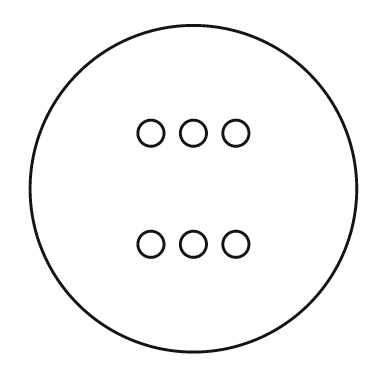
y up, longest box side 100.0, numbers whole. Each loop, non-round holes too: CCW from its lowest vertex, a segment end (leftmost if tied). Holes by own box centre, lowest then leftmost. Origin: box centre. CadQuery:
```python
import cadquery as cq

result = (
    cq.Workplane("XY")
    .moveTo(0.0, 0.0)
    .circle(50.0)
    .moveTo(-13.0, -17.0)
    .circle(4.0)
    .moveTo(0.0, -17.0)
    .circle(4.0)
    .moveTo(13.0, -17.0)
    .circle(4.0)
    .moveTo(-13.0, 17.0)
    .circle(4.0)
    .moveTo(0.0, 17.0)
    .circle(4.0)
    .moveTo(13.0, 17.0)
    .circle(4.0)
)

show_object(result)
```